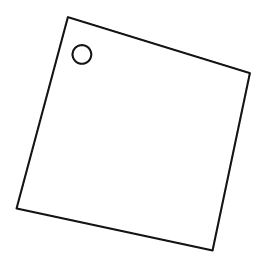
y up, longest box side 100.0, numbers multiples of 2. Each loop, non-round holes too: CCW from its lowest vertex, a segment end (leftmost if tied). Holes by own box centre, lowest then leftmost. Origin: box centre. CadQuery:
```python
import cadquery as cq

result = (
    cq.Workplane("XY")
    .moveTo(34.0, -50.0)
    .lineTo(50.0, 26.0)
    .lineTo(-28.0, 50.0)
    .lineTo(-50.0, -32.0)
    .close()
    .moveTo(-22.0, 34.0)
    .circle(4.0)
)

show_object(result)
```